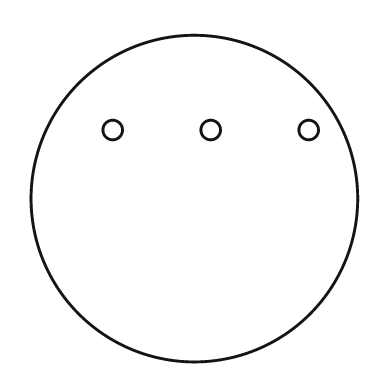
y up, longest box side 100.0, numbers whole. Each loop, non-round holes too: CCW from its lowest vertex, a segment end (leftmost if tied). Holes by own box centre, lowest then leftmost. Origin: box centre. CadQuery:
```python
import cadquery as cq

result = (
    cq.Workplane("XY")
    .moveTo(0.0, 0.0)
    .circle(50.0)
    .moveTo(-25.0, 21.0)
    .circle(3.0)
    .moveTo(5.0, 21.0)
    .circle(3.0)
    .moveTo(35.0, 21.0)
    .circle(3.0)
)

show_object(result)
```